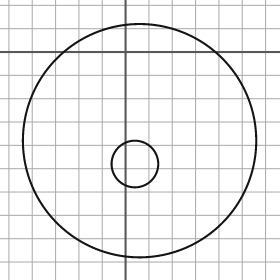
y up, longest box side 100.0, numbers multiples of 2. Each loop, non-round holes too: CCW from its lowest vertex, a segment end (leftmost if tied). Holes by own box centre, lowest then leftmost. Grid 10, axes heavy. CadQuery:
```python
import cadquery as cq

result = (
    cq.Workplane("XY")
    .moveTo(6.0, -38.0)
    .circle(50.0)
    .moveTo(4.0, -48.0)
    .circle(10.0)
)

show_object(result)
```